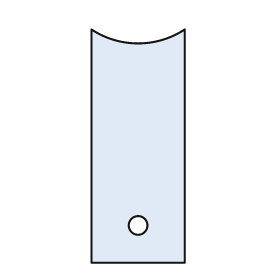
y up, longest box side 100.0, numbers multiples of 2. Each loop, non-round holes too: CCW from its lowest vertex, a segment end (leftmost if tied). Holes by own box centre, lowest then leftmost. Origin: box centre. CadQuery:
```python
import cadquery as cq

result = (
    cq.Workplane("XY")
    .moveTo(-20.0, -50.0)
    .lineTo(20.0, -50.0)
    .lineTo(20.0, 50.0)
    .threePointArc((0.0, 44.0), (-20.0, 50.0))
    .close()
    .moveTo(0.0, -34.0)
    .circle(4.0)
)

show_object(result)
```